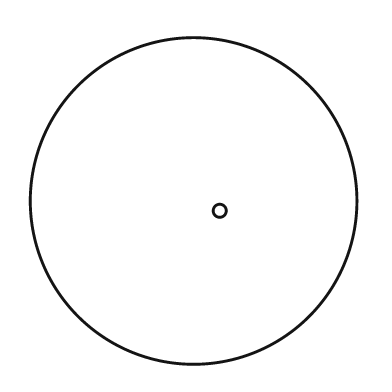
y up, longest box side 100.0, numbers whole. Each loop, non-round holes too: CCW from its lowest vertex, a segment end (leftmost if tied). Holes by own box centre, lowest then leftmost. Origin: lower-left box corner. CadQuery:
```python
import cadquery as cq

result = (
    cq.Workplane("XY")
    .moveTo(50.0, 50.0)
    .circle(50.0)
    .moveTo(58.0, 47.0)
    .circle(2.0)
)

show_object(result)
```